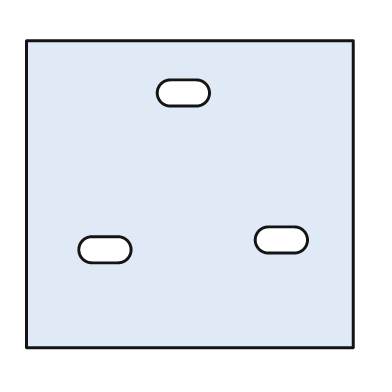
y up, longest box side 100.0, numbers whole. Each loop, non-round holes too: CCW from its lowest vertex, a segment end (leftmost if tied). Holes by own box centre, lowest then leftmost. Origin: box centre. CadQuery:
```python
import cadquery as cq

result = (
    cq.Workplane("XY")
    .moveTo(-50.0, -47.0)
    .lineTo(50.0, -47.0)
    .lineTo(50.0, 47.0)
    .lineTo(-50.0, 47.0)
    .close()
    .moveTo(-30.0, -21.0)
    .lineTo(-22.0, -21.0)
    .threePointArc((-18.0, -17.0), (-22.0, -13.0))
    .lineTo(-30.0, -13.0)
    .threePointArc((-34.0, -17.0), (-30.0, -21.0))
    .close()
    .moveTo(24.0, -18.0)
    .lineTo(32.0, -18.0)
    .threePointArc((36.0, -14.0), (32.0, -10.0))
    .lineTo(24.0, -10.0)
    .threePointArc((20.0, -14.0), (24.0, -18.0))
    .close()
    .moveTo(-6.0, 27.0)
    .lineTo(2.0, 27.0)
    .threePointArc((6.0, 31.0), (2.0, 35.0))
    .lineTo(-6.0, 35.0)
    .threePointArc((-10.0, 31.0), (-6.0, 27.0))
    .close()
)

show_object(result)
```